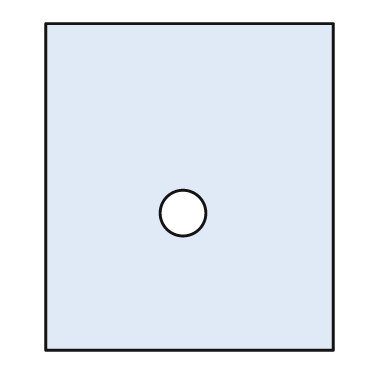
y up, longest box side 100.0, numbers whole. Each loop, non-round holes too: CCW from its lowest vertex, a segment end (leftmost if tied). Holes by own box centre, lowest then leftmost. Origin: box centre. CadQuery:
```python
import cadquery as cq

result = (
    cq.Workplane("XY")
    .moveTo(-44.0, -50.0)
    .lineTo(44.0, -50.0)
    .lineTo(44.0, 50.0)
    .lineTo(-44.0, 50.0)
    .close()
    .moveTo(-2.0, -8.0)
    .circle(7.0)
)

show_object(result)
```